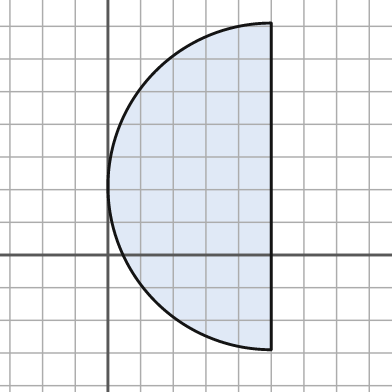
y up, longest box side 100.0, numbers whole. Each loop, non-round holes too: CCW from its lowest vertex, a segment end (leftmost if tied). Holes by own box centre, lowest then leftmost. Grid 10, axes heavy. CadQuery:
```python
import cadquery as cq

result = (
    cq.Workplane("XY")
    .moveTo(50.0, -29.0)
    .lineTo(50.0, 71.0)
    .threePointArc((0.0, 21.0), (50.0, -29.0))
    .close()
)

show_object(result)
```